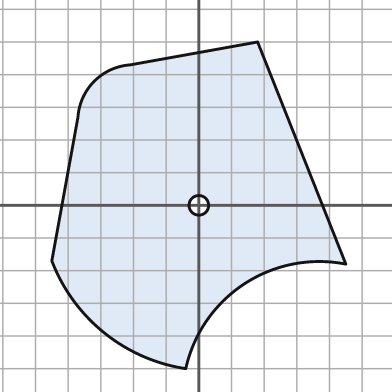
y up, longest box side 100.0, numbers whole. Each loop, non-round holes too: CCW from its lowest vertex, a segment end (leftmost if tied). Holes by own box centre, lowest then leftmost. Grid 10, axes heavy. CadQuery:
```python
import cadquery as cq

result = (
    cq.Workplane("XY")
    .moveTo(-4.0, -50.0)
    .threePointArc((14.0, -24.0), (45.0, -18.0))
    .lineTo(18.0, 50.0)
    .lineTo(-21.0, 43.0)
    .threePointArc((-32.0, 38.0), (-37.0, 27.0))
    .lineTo(-45.0, -17.0)
    .threePointArc((-29.0, -39.0), (-4.0, -50.0))
    .close()
    .moveTo(0.0, 0.0)
    .circle(3.0)
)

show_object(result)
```